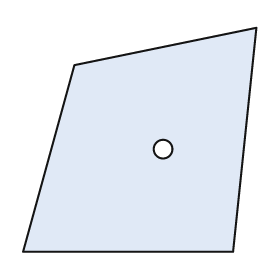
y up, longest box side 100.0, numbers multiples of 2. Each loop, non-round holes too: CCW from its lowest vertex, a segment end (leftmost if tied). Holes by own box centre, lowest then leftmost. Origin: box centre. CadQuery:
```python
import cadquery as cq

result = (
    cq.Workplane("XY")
    .moveTo(-50.0, -48.0)
    .lineTo(40.0, -48.0)
    .lineTo(50.0, 48.0)
    .lineTo(-28.0, 32.0)
    .close()
    .moveTo(10.0, -4.0)
    .circle(4.0)
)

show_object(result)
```